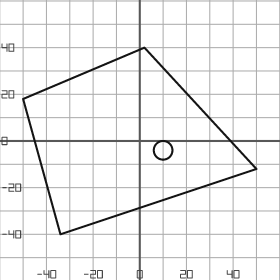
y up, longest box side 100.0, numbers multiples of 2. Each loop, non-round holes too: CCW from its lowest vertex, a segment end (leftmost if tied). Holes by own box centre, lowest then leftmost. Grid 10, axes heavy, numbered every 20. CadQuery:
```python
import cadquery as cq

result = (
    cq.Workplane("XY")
    .moveTo(-34.0, -40.0)
    .lineTo(50.0, -12.0)
    .lineTo(2.0, 40.0)
    .lineTo(-50.0, 18.0)
    .close()
    .moveTo(10.0, -4.0)
    .circle(4.0)
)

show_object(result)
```